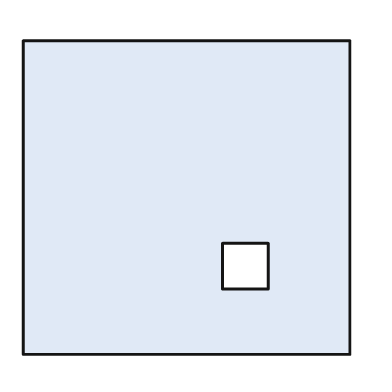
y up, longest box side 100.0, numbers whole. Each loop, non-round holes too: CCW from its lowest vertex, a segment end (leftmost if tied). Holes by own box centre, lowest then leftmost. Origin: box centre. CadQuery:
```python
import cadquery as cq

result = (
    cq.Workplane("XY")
    .moveTo(-50.0, -48.0)
    .lineTo(50.0, -48.0)
    .lineTo(50.0, 48.0)
    .lineTo(-50.0, 48.0)
    .close()
    .moveTo(11.0, -28.0)
    .lineTo(25.0, -28.0)
    .lineTo(25.0, -14.0)
    .lineTo(11.0, -14.0)
    .close()
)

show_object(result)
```